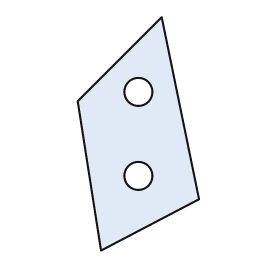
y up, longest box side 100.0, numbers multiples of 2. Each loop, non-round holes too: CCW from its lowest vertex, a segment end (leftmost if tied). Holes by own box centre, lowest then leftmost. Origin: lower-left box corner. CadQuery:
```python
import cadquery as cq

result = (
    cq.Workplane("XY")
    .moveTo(10.0, 0.0)
    .lineTo(52.0, 22.0)
    .lineTo(36.0, 100.0)
    .lineTo(0.0, 64.0)
    .close()
    .moveTo(26.0, 32.0)
    .circle(6.0)
    .moveTo(26.0, 68.0)
    .circle(6.0)
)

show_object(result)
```